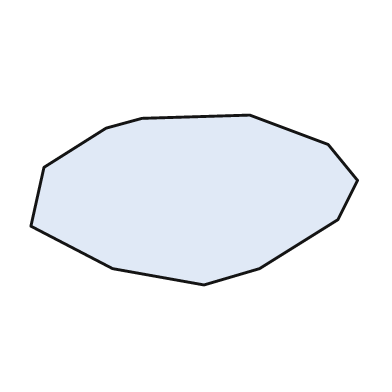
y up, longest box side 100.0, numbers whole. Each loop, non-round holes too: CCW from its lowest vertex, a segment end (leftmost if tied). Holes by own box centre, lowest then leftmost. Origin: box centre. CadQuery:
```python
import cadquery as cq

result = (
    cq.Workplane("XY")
    .moveTo(3.0, -26.0)
    .lineTo(20.0, -21.0)
    .lineTo(44.0, -6.0)
    .lineTo(50.0, 6.0)
    .lineTo(41.0, 17.0)
    .lineTo(17.0, 26.0)
    .lineTo(-16.0, 25.0)
    .lineTo(-27.0, 22.0)
    .lineTo(-46.0, 10.0)
    .lineTo(-50.0, -8.0)
    .lineTo(-25.0, -21.0)
    .close()
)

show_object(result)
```